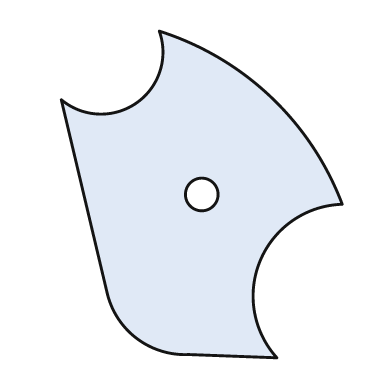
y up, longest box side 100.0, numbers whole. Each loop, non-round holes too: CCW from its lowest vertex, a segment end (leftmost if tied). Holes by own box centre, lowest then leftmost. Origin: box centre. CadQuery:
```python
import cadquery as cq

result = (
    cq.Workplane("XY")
    .moveTo(23.0, -50.0)
    .threePointArc((18.0, -20.0), (43.0, -3.0))
    .threePointArc((21.0, 30.0), (-13.0, 50.0))
    .threePointArc((-20.0, 28.0), (-43.0, 29.0))
    .lineTo(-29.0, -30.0)
    .threePointArc((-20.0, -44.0), (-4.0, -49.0))
    .close()
    .moveTo(0.0, 0.0)
    .circle(5.0)
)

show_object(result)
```